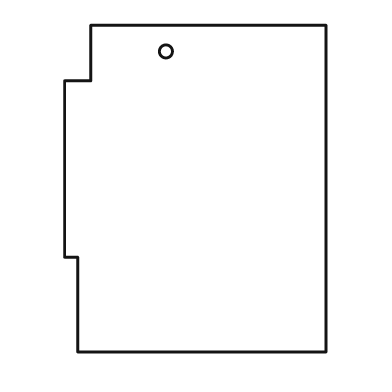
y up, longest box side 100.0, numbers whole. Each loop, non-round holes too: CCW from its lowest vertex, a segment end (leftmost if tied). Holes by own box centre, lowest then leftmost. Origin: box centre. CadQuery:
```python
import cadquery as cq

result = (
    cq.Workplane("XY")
    .moveTo(-36.0, -50.0)
    .lineTo(40.0, -50.0)
    .lineTo(40.0, 50.0)
    .lineTo(-32.0, 50.0)
    .lineTo(-32.0, 33.0)
    .lineTo(-40.0, 33.0)
    .lineTo(-40.0, -21.0)
    .lineTo(-36.0, -21.0)
    .close()
    .moveTo(-9.0, 42.0)
    .circle(2.0)
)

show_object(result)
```